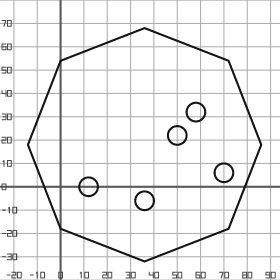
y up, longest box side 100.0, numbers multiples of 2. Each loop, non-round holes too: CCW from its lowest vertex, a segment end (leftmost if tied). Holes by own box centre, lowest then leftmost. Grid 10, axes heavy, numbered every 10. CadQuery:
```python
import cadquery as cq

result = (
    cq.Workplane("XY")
    .moveTo(36.0, -32.0)
    .lineTo(72.0, -18.0)
    .lineTo(86.0, 18.0)
    .lineTo(72.0, 54.0)
    .lineTo(36.0, 68.0)
    .lineTo(0.0, 54.0)
    .lineTo(-14.0, 18.0)
    .lineTo(0.0, -18.0)
    .close()
    .moveTo(36.0, -6.0)
    .circle(4.0)
    .moveTo(12.0, 0.0)
    .circle(4.0)
    .moveTo(70.0, 6.0)
    .circle(4.0)
    .moveTo(50.0, 22.0)
    .circle(4.0)
    .moveTo(58.0, 32.0)
    .circle(4.0)
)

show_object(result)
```